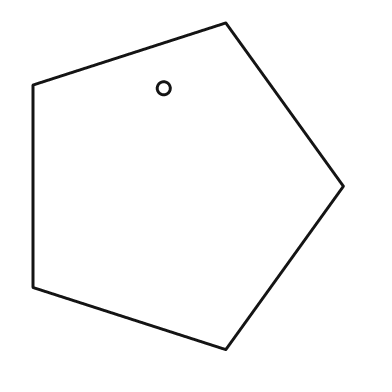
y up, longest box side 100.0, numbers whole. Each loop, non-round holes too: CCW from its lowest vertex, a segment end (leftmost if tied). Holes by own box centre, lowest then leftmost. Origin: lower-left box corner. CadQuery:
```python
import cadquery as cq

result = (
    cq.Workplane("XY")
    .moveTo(59.0, 0.0)
    .lineTo(95.0, 50.0)
    .lineTo(59.0, 100.0)
    .lineTo(0.0, 81.0)
    .lineTo(0.0, 19.0)
    .close()
    .moveTo(40.0, 80.0)
    .circle(2.0)
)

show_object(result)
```